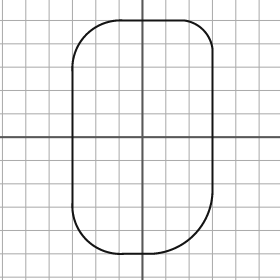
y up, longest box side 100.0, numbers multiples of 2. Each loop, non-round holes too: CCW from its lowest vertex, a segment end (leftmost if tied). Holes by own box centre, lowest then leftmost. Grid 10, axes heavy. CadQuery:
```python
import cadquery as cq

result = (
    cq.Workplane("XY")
    .moveTo(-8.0, -50.0)
    .lineTo(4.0, -50.0)
    .threePointArc((22.0, -42.0), (30.0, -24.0))
    .lineTo(30.0, 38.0)
    .threePointArc((26.0, 46.0), (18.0, 50.0))
    .lineTo(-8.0, 50.0)
    .threePointArc((-24.0, 44.0), (-30.0, 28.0))
    .lineTo(-30.0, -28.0)
    .threePointArc((-24.0, -44.0), (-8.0, -50.0))
    .close()
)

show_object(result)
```